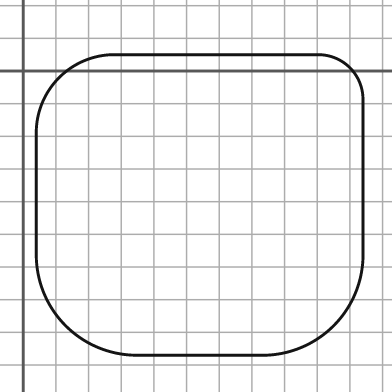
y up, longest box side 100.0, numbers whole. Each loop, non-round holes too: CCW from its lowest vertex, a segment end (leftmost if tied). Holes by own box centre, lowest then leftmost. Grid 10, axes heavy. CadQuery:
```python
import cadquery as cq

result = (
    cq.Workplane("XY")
    .moveTo(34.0, -87.0)
    .lineTo(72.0, -87.0)
    .threePointArc((95.0, -78.0), (104.0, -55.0))
    .lineTo(104.0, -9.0)
    .threePointArc((100.0, 1.0), (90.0, 5.0))
    .lineTo(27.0, 5.0)
    .threePointArc((11.0, -2.0), (4.0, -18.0))
    .lineTo(4.0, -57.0)
    .threePointArc((13.0, -78.0), (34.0, -87.0))
    .close()
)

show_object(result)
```